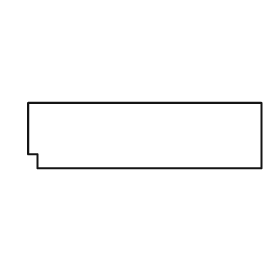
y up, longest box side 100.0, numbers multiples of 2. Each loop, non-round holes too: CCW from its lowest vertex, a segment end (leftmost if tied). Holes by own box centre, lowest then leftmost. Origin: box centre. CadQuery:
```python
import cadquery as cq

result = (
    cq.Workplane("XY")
    .moveTo(-46.0, -14.0)
    .lineTo(50.0, -14.0)
    .lineTo(50.0, 14.0)
    .lineTo(-50.0, 14.0)
    .lineTo(-50.0, -8.0)
    .lineTo(-46.0, -8.0)
    .close()
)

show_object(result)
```